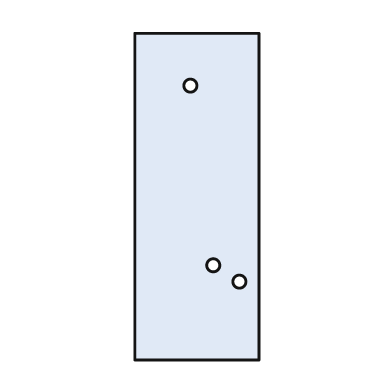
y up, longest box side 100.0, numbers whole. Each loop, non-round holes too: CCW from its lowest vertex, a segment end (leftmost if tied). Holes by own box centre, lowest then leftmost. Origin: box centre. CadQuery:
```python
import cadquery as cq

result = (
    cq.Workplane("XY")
    .moveTo(-19.0, -50.0)
    .lineTo(19.0, -50.0)
    .lineTo(19.0, 50.0)
    .lineTo(-19.0, 50.0)
    .close()
    .moveTo(13.0, -26.0)
    .circle(2.0)
    .moveTo(5.0, -21.0)
    .circle(2.0)
    .moveTo(-2.0, 34.0)
    .circle(2.0)
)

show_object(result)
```